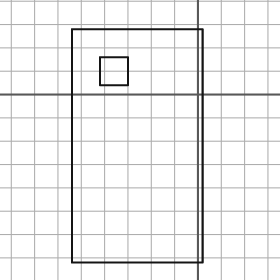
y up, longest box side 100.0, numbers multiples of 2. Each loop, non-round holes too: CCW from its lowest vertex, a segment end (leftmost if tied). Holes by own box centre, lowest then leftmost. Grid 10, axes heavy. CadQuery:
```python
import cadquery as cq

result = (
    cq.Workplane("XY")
    .moveTo(-54.0, -72.0)
    .lineTo(2.0, -72.0)
    .lineTo(2.0, 28.0)
    .lineTo(-54.0, 28.0)
    .close()
    .moveTo(-42.0, 4.0)
    .lineTo(-30.0, 4.0)
    .lineTo(-30.0, 16.0)
    .lineTo(-42.0, 16.0)
    .close()
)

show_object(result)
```